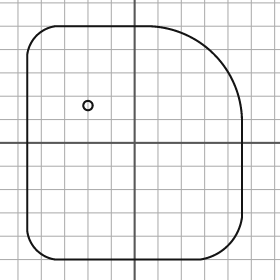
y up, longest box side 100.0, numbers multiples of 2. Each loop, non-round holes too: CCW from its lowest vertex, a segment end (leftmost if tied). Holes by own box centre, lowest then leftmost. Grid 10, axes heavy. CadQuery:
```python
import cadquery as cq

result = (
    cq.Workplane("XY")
    .moveTo(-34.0, -50.0)
    .lineTo(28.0, -50.0)
    .threePointArc((40.0, -44.0), (46.0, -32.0))
    .lineTo(46.0, 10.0)
    .threePointArc((34.0, 38.0), (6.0, 50.0))
    .lineTo(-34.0, 50.0)
    .threePointArc((-42.0, 46.0), (-46.0, 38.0))
    .lineTo(-46.0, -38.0)
    .threePointArc((-42.0, -46.0), (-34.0, -50.0))
    .close()
    .moveTo(-20.0, 16.0)
    .circle(2.0)
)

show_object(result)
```